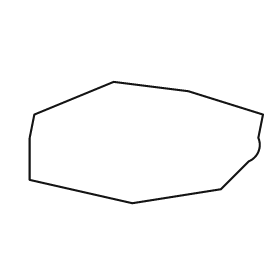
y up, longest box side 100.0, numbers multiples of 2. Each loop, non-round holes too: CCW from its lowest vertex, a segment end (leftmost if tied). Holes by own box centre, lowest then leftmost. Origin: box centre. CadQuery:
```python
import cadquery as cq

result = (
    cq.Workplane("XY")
    .moveTo(-6.0, -26.0)
    .lineTo(32.0, -20.0)
    .lineTo(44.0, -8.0)
    .threePointArc((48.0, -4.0), (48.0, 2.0))
    .lineTo(50.0, 12.0)
    .lineTo(18.0, 22.0)
    .lineTo(-14.0, 26.0)
    .lineTo(-48.0, 12.0)
    .lineTo(-50.0, 2.0)
    .lineTo(-50.0, -16.0)
    .close()
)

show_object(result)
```